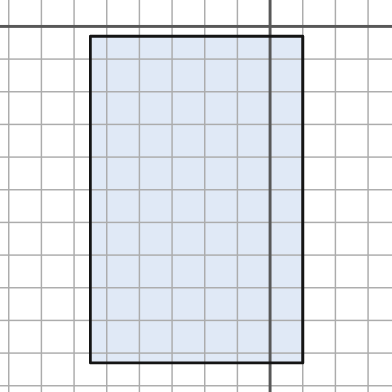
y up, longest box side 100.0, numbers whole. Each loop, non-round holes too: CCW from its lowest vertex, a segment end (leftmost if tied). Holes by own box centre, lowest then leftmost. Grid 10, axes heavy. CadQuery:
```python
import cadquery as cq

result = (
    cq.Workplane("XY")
    .moveTo(-55.0, -103.0)
    .lineTo(10.0, -103.0)
    .lineTo(10.0, -3.0)
    .lineTo(-55.0, -3.0)
    .close()
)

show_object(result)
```